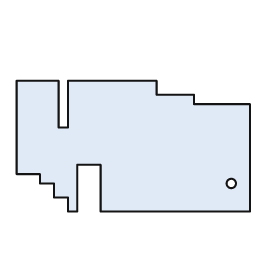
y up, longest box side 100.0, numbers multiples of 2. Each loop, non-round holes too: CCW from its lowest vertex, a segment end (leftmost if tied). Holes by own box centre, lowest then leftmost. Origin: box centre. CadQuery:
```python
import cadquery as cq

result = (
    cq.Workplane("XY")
    .moveTo(-28.0, -28.0)
    .lineTo(-24.0, -28.0)
    .lineTo(-24.0, -8.0)
    .lineTo(-14.0, -8.0)
    .lineTo(-14.0, -28.0)
    .lineTo(50.0, -28.0)
    .lineTo(50.0, 18.0)
    .lineTo(26.0, 18.0)
    .lineTo(26.0, 22.0)
    .lineTo(10.0, 22.0)
    .lineTo(10.0, 28.0)
    .lineTo(-28.0, 28.0)
    .lineTo(-28.0, 8.0)
    .lineTo(-32.0, 8.0)
    .lineTo(-32.0, 28.0)
    .lineTo(-50.0, 28.0)
    .lineTo(-50.0, -12.0)
    .lineTo(-40.0, -12.0)
    .lineTo(-40.0, -16.0)
    .lineTo(-34.0, -16.0)
    .lineTo(-34.0, -22.0)
    .lineTo(-28.0, -22.0)
    .close()
    .moveTo(42.0, -16.0)
    .circle(2.0)
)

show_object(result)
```